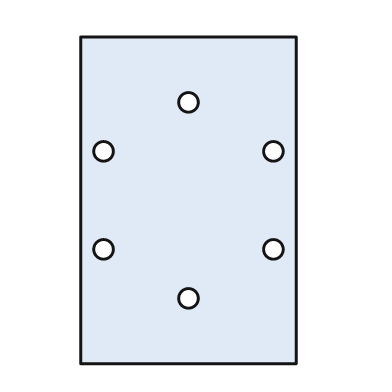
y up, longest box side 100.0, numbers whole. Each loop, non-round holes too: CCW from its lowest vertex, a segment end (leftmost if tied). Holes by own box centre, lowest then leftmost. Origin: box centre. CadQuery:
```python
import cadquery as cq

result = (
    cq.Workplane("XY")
    .moveTo(-33.0, -50.0)
    .lineTo(33.0, -50.0)
    .lineTo(33.0, 50.0)
    .lineTo(-33.0, 50.0)
    .close()
    .moveTo(0.0, -30.0)
    .circle(3.0)
    .moveTo(-26.0, -15.0)
    .circle(3.0)
    .moveTo(26.0, -15.0)
    .circle(3.0)
    .moveTo(-26.0, 15.0)
    .circle(3.0)
    .moveTo(26.0, 15.0)
    .circle(3.0)
    .moveTo(0.0, 30.0)
    .circle(3.0)
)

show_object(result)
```